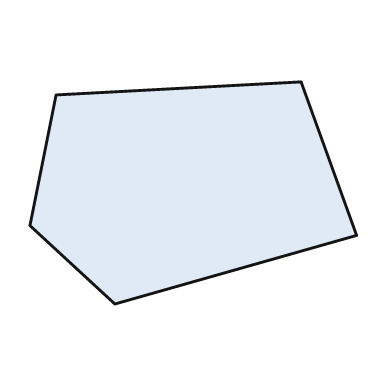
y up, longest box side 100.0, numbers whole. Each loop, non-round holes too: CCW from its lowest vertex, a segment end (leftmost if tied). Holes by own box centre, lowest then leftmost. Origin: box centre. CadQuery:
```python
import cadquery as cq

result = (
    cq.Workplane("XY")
    .moveTo(-24.0, -34.0)
    .lineTo(50.0, -13.0)
    .lineTo(33.0, 34.0)
    .lineTo(-42.0, 30.0)
    .lineTo(-50.0, -10.0)
    .close()
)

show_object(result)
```